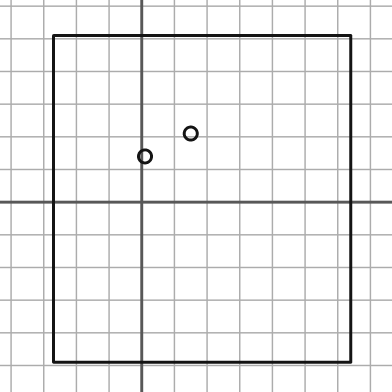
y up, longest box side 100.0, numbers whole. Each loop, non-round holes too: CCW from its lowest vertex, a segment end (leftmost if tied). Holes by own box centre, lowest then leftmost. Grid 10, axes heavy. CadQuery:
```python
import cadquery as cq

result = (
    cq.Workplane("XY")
    .moveTo(-27.0, -49.0)
    .lineTo(64.0, -49.0)
    .lineTo(64.0, 51.0)
    .lineTo(-27.0, 51.0)
    .close()
    .moveTo(1.0, 14.0)
    .circle(2.0)
    .moveTo(15.0, 21.0)
    .circle(2.0)
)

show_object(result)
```